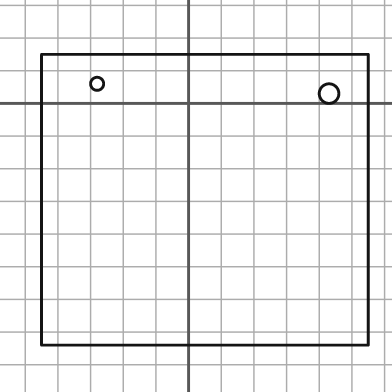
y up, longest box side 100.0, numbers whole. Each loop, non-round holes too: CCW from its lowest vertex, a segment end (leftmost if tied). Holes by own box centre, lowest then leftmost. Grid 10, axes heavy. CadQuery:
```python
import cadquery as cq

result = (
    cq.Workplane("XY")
    .moveTo(-45.0, -74.0)
    .lineTo(55.0, -74.0)
    .lineTo(55.0, 15.0)
    .lineTo(-45.0, 15.0)
    .close()
    .moveTo(43.0, 3.0)
    .circle(3.0)
    .moveTo(-28.0, 6.0)
    .circle(2.0)
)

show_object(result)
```